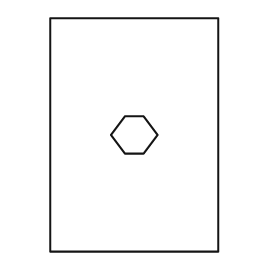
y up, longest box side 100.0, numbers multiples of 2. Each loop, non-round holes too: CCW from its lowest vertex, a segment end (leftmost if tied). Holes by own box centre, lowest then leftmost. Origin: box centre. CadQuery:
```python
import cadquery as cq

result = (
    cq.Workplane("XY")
    .moveTo(-36.0, -50.0)
    .lineTo(36.0, -50.0)
    .lineTo(36.0, 50.0)
    .lineTo(-36.0, 50.0)
    .close()
    .moveTo(-4.0, -8.0)
    .lineTo(4.0, -8.0)
    .lineTo(10.0, 0.0)
    .lineTo(4.0, 8.0)
    .lineTo(-4.0, 8.0)
    .lineTo(-10.0, 0.0)
    .close()
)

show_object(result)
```